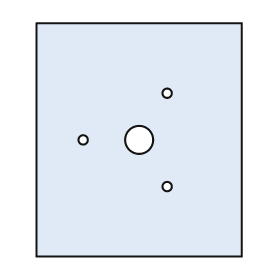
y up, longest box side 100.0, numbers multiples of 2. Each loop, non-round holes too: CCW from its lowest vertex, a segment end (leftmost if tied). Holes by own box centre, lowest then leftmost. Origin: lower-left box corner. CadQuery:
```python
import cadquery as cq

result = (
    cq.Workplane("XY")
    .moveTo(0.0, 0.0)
    .lineTo(88.0, 0.0)
    .lineTo(88.0, 100.0)
    .lineTo(0.0, 100.0)
    .close()
    .moveTo(56.0, 30.0)
    .circle(2.0)
    .moveTo(20.0, 50.0)
    .circle(2.0)
    .moveTo(44.0, 50.0)
    .circle(6.0)
    .moveTo(56.0, 70.0)
    .circle(2.0)
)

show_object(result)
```